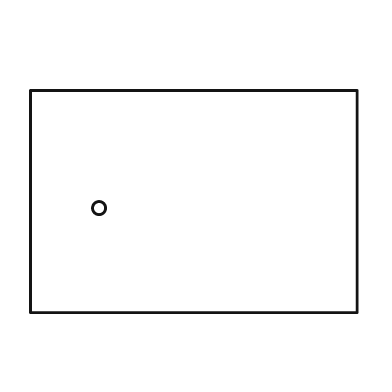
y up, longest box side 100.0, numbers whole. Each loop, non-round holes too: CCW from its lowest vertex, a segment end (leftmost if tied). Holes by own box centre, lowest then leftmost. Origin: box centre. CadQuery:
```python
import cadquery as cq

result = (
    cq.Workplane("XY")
    .moveTo(-50.0, -34.0)
    .lineTo(50.0, -34.0)
    .lineTo(50.0, 34.0)
    .lineTo(-50.0, 34.0)
    .close()
    .moveTo(-29.0, -2.0)
    .circle(2.0)
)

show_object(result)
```